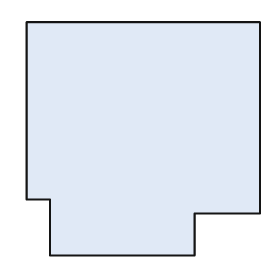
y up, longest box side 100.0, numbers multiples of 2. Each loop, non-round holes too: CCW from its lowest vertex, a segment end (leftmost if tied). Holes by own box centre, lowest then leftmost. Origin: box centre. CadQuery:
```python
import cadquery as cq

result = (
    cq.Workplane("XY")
    .moveTo(-40.0, -50.0)
    .lineTo(22.0, -50.0)
    .lineTo(22.0, -32.0)
    .lineTo(50.0, -32.0)
    .lineTo(50.0, 50.0)
    .lineTo(-50.0, 50.0)
    .lineTo(-50.0, -26.0)
    .lineTo(-40.0, -26.0)
    .close()
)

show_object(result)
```